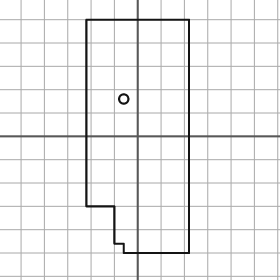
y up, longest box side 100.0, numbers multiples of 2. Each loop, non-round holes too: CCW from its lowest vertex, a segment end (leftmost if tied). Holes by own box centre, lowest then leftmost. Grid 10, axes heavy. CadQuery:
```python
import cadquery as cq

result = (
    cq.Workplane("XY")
    .moveTo(-6.0, -50.0)
    .lineTo(22.0, -50.0)
    .lineTo(22.0, 50.0)
    .lineTo(-22.0, 50.0)
    .lineTo(-22.0, -30.0)
    .lineTo(-10.0, -30.0)
    .lineTo(-10.0, -46.0)
    .lineTo(-6.0, -46.0)
    .close()
    .moveTo(-6.0, 16.0)
    .circle(2.0)
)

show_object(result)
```